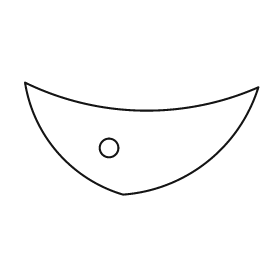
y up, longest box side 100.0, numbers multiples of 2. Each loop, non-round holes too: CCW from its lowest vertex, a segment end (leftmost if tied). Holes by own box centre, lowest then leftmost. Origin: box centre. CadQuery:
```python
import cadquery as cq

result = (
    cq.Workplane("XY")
    .moveTo(-8.0, -24.0)
    .threePointArc((28.0, -10.0), (50.0, 22.0))
    .threePointArc((0.0, 12.0), (-50.0, 24.0))
    .threePointArc((-36.0, -6.0), (-8.0, -24.0))
    .close()
    .moveTo(-14.0, -4.0)
    .circle(4.0)
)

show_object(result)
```